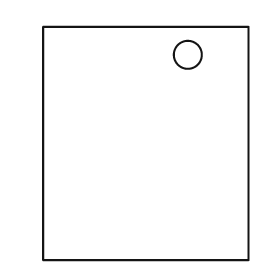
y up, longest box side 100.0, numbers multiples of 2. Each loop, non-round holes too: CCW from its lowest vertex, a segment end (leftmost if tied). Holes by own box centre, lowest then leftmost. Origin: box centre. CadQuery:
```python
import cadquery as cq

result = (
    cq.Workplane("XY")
    .moveTo(-44.0, -50.0)
    .lineTo(44.0, -50.0)
    .lineTo(44.0, 50.0)
    .lineTo(-44.0, 50.0)
    .close()
    .moveTo(18.0, 38.0)
    .circle(6.0)
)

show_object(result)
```